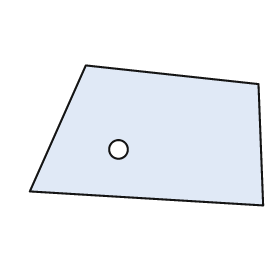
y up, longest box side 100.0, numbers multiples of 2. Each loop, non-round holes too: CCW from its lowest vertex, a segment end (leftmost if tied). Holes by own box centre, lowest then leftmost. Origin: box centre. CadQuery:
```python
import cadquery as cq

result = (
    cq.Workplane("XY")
    .moveTo(50.0, -30.0)
    .lineTo(48.0, 22.0)
    .lineTo(-26.0, 30.0)
    .lineTo(-50.0, -24.0)
    .close()
    .moveTo(-12.0, -6.0)
    .circle(4.0)
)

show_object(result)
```